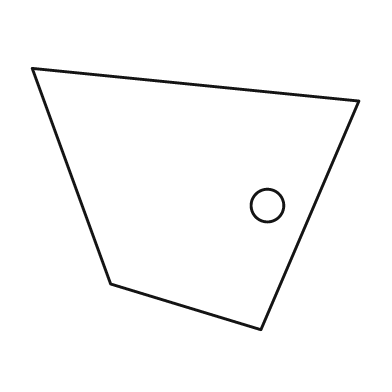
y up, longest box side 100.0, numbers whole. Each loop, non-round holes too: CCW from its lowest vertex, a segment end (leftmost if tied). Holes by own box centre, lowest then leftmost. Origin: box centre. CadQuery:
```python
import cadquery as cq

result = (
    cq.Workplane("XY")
    .moveTo(20.0, -40.0)
    .lineTo(50.0, 30.0)
    .lineTo(-50.0, 40.0)
    .lineTo(-26.0, -26.0)
    .close()
    .moveTo(22.0, -2.0)
    .circle(5.0)
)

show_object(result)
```